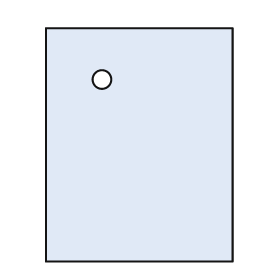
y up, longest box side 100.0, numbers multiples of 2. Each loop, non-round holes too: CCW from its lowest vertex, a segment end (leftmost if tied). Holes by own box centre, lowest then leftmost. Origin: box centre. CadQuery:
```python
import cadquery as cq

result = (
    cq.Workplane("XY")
    .moveTo(-40.0, -50.0)
    .lineTo(40.0, -50.0)
    .lineTo(40.0, 50.0)
    .lineTo(-40.0, 50.0)
    .close()
    .moveTo(-16.0, 28.0)
    .circle(4.0)
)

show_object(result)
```